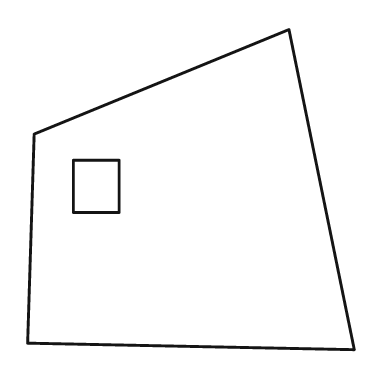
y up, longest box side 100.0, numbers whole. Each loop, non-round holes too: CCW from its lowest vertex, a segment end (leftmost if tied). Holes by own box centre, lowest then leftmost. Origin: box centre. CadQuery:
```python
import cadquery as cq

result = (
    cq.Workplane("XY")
    .moveTo(50.0, -49.0)
    .lineTo(30.0, 49.0)
    .lineTo(-48.0, 17.0)
    .lineTo(-50.0, -47.0)
    .close()
    .moveTo(-36.0, -7.0)
    .lineTo(-22.0, -7.0)
    .lineTo(-22.0, 9.0)
    .lineTo(-36.0, 9.0)
    .close()
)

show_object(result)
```